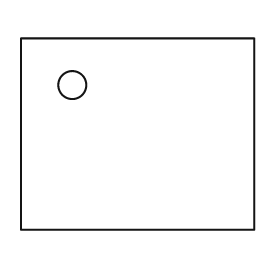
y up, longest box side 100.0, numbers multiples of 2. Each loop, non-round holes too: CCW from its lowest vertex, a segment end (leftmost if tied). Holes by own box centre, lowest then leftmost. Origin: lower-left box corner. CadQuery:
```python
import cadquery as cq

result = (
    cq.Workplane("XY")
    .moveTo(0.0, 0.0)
    .lineTo(100.0, 0.0)
    .lineTo(100.0, 82.0)
    .lineTo(0.0, 82.0)
    .close()
    .moveTo(22.0, 62.0)
    .circle(6.0)
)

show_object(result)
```